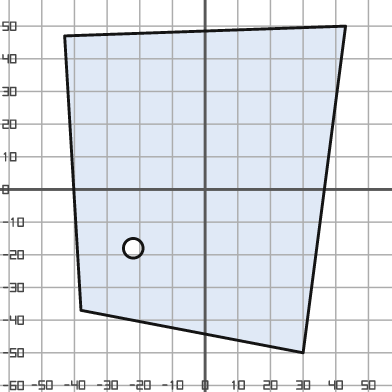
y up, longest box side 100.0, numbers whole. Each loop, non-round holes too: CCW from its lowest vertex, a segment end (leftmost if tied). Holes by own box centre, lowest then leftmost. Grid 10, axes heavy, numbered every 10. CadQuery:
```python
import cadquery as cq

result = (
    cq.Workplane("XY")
    .moveTo(30.0, -50.0)
    .lineTo(43.0, 50.0)
    .lineTo(-43.0, 47.0)
    .lineTo(-38.0, -37.0)
    .close()
    .moveTo(-22.0, -18.0)
    .circle(3.0)
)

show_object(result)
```